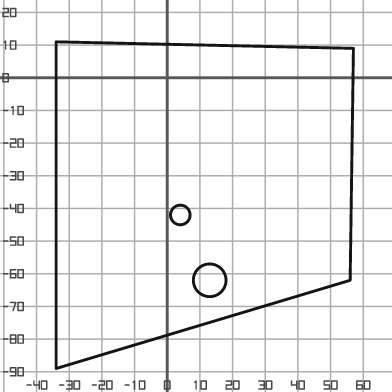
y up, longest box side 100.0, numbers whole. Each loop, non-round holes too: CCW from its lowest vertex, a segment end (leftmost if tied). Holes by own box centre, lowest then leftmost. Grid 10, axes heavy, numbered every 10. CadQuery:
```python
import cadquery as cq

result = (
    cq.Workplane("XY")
    .moveTo(-34.0, -89.0)
    .lineTo(56.0, -62.0)
    .lineTo(57.0, 9.0)
    .lineTo(-34.0, 11.0)
    .close()
    .moveTo(13.0, -62.0)
    .circle(5.0)
    .moveTo(4.0, -42.0)
    .circle(3.0)
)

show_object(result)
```